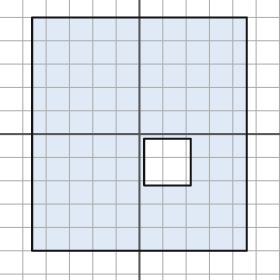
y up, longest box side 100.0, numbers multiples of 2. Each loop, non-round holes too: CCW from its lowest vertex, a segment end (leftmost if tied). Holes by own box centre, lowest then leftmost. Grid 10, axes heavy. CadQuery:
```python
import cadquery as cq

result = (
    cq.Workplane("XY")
    .moveTo(-46.0, -50.0)
    .lineTo(46.0, -50.0)
    .lineTo(46.0, 50.0)
    .lineTo(-46.0, 50.0)
    .close()
    .moveTo(2.0, -22.0)
    .lineTo(22.0, -22.0)
    .lineTo(22.0, -2.0)
    .lineTo(2.0, -2.0)
    .close()
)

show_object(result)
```